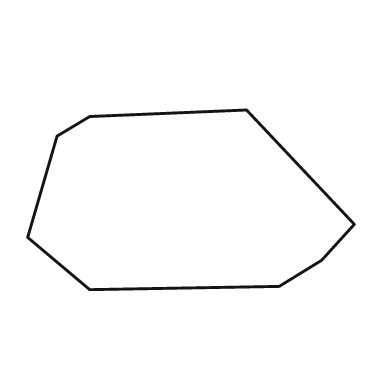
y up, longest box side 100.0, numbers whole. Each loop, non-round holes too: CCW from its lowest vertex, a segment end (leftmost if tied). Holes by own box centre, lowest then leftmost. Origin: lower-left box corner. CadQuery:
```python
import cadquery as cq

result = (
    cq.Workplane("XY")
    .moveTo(19.0, 0.0)
    .lineTo(77.0, 1.0)
    .lineTo(90.0, 9.0)
    .lineTo(100.0, 20.0)
    .lineTo(67.0, 55.0)
    .lineTo(19.0, 53.0)
    .lineTo(9.0, 47.0)
    .lineTo(0.0, 16.0)
    .close()
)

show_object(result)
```